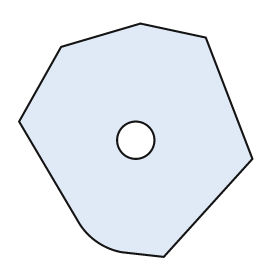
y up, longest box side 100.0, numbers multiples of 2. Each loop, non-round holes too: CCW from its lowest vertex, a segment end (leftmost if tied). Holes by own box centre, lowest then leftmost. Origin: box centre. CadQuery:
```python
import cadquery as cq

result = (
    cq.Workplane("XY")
    .moveTo(12.0, -50.0)
    .lineTo(50.0, -8.0)
    .lineTo(30.0, 44.0)
    .lineTo(2.0, 50.0)
    .lineTo(-32.0, 40.0)
    .lineTo(-50.0, 8.0)
    .lineTo(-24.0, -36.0)
    .threePointArc((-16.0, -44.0), (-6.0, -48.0))
    .close()
    .moveTo(0.0, 0.0)
    .circle(8.0)
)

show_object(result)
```